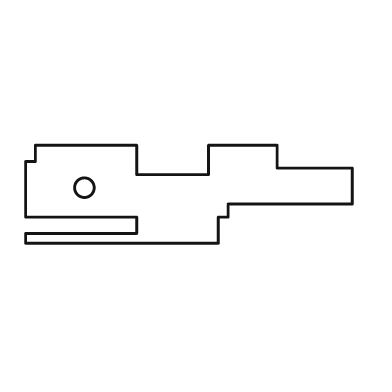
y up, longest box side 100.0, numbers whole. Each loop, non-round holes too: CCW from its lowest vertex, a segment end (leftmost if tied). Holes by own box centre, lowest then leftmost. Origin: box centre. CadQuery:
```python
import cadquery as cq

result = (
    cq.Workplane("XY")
    .moveTo(-50.0, -15.0)
    .lineTo(9.0, -15.0)
    .lineTo(9.0, -7.0)
    .lineTo(12.0, -7.0)
    .lineTo(12.0, -3.0)
    .lineTo(50.0, -3.0)
    .lineTo(50.0, 8.0)
    .lineTo(27.0, 8.0)
    .lineTo(27.0, 15.0)
    .lineTo(6.0, 15.0)
    .lineTo(6.0, 6.0)
    .lineTo(-16.0, 6.0)
    .lineTo(-16.0, 15.0)
    .lineTo(-47.0, 15.0)
    .lineTo(-47.0, 10.0)
    .lineTo(-50.0, 10.0)
    .lineTo(-50.0, -7.0)
    .lineTo(-16.0, -7.0)
    .lineTo(-16.0, -12.0)
    .lineTo(-50.0, -12.0)
    .close()
    .moveTo(-32.0, 2.0)
    .circle(3.0)
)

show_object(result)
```